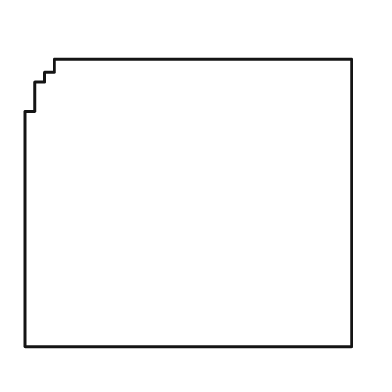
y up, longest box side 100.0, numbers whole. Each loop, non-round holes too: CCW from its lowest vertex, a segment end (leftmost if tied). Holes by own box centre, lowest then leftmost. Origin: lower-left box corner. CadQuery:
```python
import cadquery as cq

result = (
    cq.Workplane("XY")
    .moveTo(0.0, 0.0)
    .lineTo(100.0, 0.0)
    .lineTo(100.0, 88.0)
    .lineTo(9.0, 88.0)
    .lineTo(9.0, 84.0)
    .lineTo(6.0, 84.0)
    .lineTo(6.0, 81.0)
    .lineTo(3.0, 81.0)
    .lineTo(3.0, 72.0)
    .lineTo(0.0, 72.0)
    .close()
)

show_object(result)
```